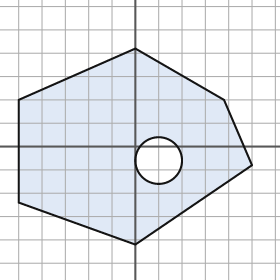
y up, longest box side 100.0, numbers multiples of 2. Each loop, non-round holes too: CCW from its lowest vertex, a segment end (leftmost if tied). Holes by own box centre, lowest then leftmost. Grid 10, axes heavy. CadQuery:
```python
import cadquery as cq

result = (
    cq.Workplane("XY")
    .moveTo(0.0, -42.0)
    .lineTo(50.0, -8.0)
    .lineTo(38.0, 20.0)
    .lineTo(0.0, 42.0)
    .lineTo(-50.0, 20.0)
    .lineTo(-50.0, -24.0)
    .close()
    .moveTo(10.0, -6.0)
    .circle(10.0)
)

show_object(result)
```